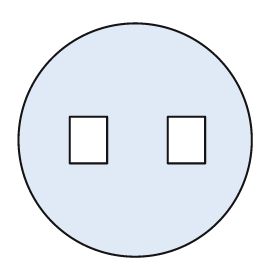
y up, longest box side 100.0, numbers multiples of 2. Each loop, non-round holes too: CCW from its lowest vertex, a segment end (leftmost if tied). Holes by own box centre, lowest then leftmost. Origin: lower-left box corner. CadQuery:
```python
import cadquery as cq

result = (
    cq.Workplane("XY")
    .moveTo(50.0, 50.0)
    .circle(50.0)
    .moveTo(22.0, 40.0)
    .lineTo(38.0, 40.0)
    .lineTo(38.0, 60.0)
    .lineTo(22.0, 60.0)
    .close()
    .moveTo(64.0, 40.0)
    .lineTo(80.0, 40.0)
    .lineTo(80.0, 60.0)
    .lineTo(64.0, 60.0)
    .close()
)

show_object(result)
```